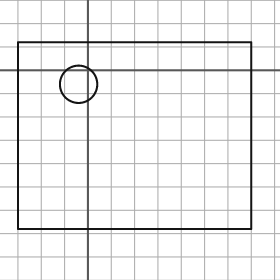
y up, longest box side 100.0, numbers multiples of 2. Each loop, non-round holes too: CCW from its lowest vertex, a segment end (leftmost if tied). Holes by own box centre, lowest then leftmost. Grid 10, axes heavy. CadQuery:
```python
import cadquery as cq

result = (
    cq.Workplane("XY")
    .moveTo(-30.0, -68.0)
    .lineTo(70.0, -68.0)
    .lineTo(70.0, 12.0)
    .lineTo(-30.0, 12.0)
    .close()
    .moveTo(-4.0, -6.0)
    .circle(8.0)
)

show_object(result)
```